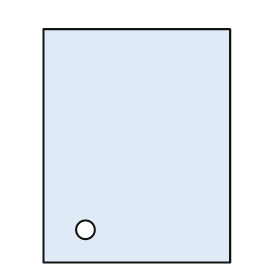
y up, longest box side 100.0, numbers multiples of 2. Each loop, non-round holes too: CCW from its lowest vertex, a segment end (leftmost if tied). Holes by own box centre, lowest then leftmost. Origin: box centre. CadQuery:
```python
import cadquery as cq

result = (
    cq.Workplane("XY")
    .moveTo(-40.0, -50.0)
    .lineTo(40.0, -50.0)
    .lineTo(40.0, 50.0)
    .lineTo(-40.0, 50.0)
    .close()
    .moveTo(-22.0, -36.0)
    .circle(4.0)
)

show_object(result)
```